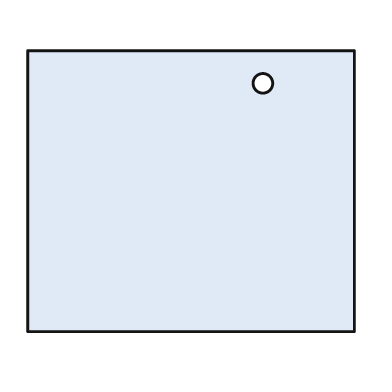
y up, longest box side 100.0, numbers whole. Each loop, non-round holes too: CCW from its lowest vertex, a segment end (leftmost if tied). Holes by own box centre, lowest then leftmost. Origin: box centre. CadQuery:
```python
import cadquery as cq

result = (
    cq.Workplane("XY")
    .moveTo(-50.0, -43.0)
    .lineTo(50.0, -43.0)
    .lineTo(50.0, 43.0)
    .lineTo(-50.0, 43.0)
    .close()
    .moveTo(22.0, 33.0)
    .circle(3.0)
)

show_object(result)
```